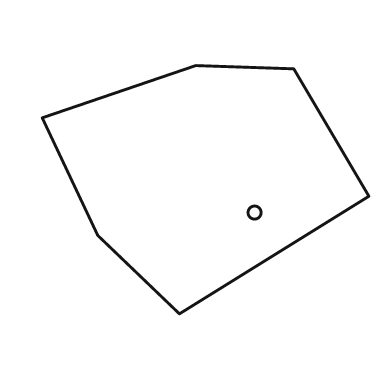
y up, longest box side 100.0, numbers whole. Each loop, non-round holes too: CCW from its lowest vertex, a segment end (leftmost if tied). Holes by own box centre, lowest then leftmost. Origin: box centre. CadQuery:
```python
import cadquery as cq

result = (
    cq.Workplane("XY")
    .moveTo(-8.0, -38.0)
    .lineTo(50.0, -2.0)
    .lineTo(27.0, 37.0)
    .lineTo(-3.0, 38.0)
    .lineTo(-50.0, 22.0)
    .lineTo(-33.0, -14.0)
    .close()
    .moveTo(15.0, -7.0)
    .circle(2.0)
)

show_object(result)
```